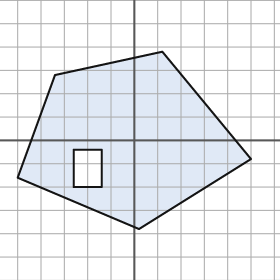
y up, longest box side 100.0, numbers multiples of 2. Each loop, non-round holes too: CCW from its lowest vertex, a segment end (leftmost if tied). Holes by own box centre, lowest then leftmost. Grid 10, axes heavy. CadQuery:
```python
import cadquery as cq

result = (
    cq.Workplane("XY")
    .moveTo(2.0, -38.0)
    .lineTo(50.0, -8.0)
    .lineTo(12.0, 38.0)
    .lineTo(-34.0, 28.0)
    .lineTo(-50.0, -16.0)
    .close()
    .moveTo(-26.0, -20.0)
    .lineTo(-14.0, -20.0)
    .lineTo(-14.0, -4.0)
    .lineTo(-26.0, -4.0)
    .close()
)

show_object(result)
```